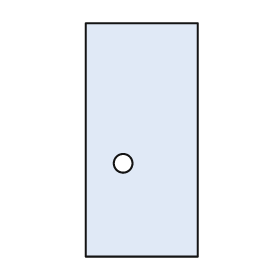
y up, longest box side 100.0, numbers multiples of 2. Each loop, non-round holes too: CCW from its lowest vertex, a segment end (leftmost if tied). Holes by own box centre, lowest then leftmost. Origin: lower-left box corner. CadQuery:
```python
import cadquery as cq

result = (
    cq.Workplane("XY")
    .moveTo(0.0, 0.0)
    .lineTo(48.0, 0.0)
    .lineTo(48.0, 100.0)
    .lineTo(0.0, 100.0)
    .close()
    .moveTo(16.0, 40.0)
    .circle(4.0)
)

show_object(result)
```